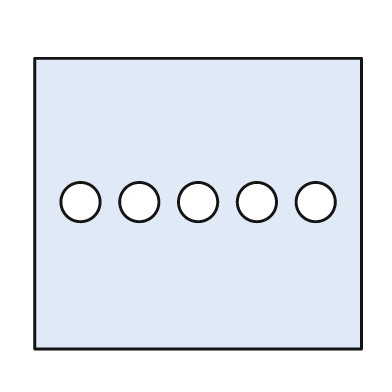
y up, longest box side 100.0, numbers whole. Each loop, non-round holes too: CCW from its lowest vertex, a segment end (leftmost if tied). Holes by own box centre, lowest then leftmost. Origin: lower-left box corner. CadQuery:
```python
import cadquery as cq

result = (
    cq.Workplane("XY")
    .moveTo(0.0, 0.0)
    .lineTo(100.0, 0.0)
    .lineTo(100.0, 89.0)
    .lineTo(0.0, 89.0)
    .close()
    .moveTo(14.0, 45.0)
    .circle(6.0)
    .moveTo(32.0, 45.0)
    .circle(6.0)
    .moveTo(50.0, 45.0)
    .circle(6.0)
    .moveTo(68.0, 45.0)
    .circle(6.0)
    .moveTo(86.0, 45.0)
    .circle(6.0)
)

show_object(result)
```